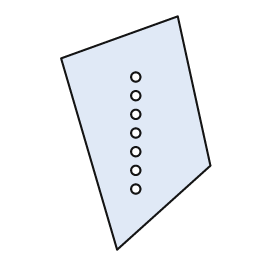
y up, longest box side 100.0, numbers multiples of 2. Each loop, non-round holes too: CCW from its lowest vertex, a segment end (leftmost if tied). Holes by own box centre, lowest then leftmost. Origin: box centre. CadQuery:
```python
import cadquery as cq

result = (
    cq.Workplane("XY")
    .moveTo(-8.0, -50.0)
    .lineTo(32.0, -14.0)
    .lineTo(18.0, 50.0)
    .lineTo(-32.0, 32.0)
    .close()
    .moveTo(0.0, -24.0)
    .circle(2.0)
    .moveTo(0.0, -16.0)
    .circle(2.0)
    .moveTo(0.0, -8.0)
    .circle(2.0)
    .moveTo(0.0, 0.0)
    .circle(2.0)
    .moveTo(0.0, 8.0)
    .circle(2.0)
    .moveTo(0.0, 16.0)
    .circle(2.0)
    .moveTo(0.0, 24.0)
    .circle(2.0)
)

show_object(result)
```